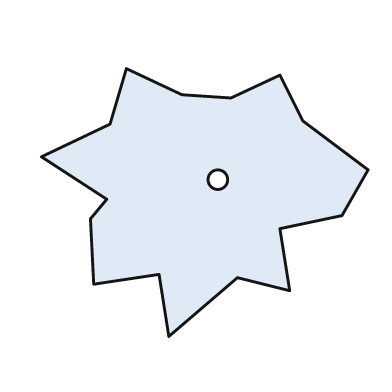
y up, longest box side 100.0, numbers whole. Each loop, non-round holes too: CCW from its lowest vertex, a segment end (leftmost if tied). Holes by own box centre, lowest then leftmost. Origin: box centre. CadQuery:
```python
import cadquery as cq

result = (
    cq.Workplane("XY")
    .moveTo(-11.0, -41.0)
    .lineTo(10.0, -23.0)
    .lineTo(26.0, -27.0)
    .lineTo(23.0, -8.0)
    .lineTo(42.0, -4.0)
    .lineTo(50.0, 10.0)
    .lineTo(30.0, 25.0)
    .lineTo(23.0, 39.0)
    .lineTo(8.0, 32.0)
    .lineTo(-7.0, 33.0)
    .lineTo(-24.0, 41.0)
    .lineTo(-29.0, 24.0)
    .lineTo(-50.0, 14.0)
    .lineTo(-30.0, 1.0)
    .lineTo(-35.0, -5.0)
    .lineTo(-34.0, -25.0)
    .lineTo(-14.0, -22.0)
    .close()
    .moveTo(4.0, 7.0)
    .circle(3.0)
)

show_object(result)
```